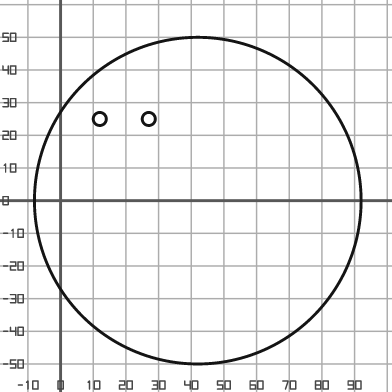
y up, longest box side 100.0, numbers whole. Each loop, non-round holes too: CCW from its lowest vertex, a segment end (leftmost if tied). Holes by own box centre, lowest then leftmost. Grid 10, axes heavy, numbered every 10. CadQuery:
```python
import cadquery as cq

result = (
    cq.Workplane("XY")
    .moveTo(42.0, 0.0)
    .circle(50.0)
    .moveTo(12.0, 25.0)
    .circle(2.0)
    .moveTo(27.0, 25.0)
    .circle(2.0)
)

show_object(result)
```